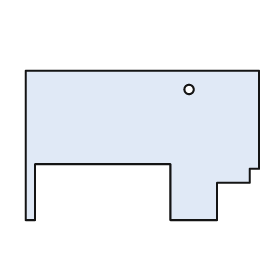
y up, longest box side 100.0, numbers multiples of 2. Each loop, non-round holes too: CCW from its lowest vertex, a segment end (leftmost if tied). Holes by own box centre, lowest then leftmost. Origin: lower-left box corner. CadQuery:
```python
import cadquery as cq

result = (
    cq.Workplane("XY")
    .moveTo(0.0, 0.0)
    .lineTo(4.0, 0.0)
    .lineTo(4.0, 24.0)
    .lineTo(62.0, 24.0)
    .lineTo(62.0, 0.0)
    .lineTo(82.0, 0.0)
    .lineTo(82.0, 16.0)
    .lineTo(96.0, 16.0)
    .lineTo(96.0, 22.0)
    .lineTo(100.0, 22.0)
    .lineTo(100.0, 64.0)
    .lineTo(0.0, 64.0)
    .close()
    .moveTo(70.0, 56.0)
    .circle(2.0)
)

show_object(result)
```